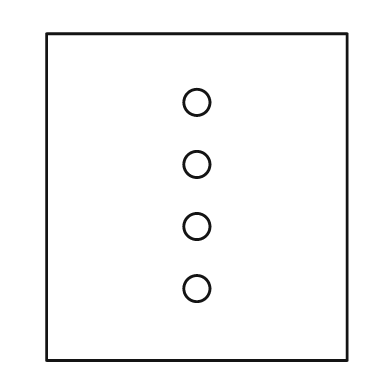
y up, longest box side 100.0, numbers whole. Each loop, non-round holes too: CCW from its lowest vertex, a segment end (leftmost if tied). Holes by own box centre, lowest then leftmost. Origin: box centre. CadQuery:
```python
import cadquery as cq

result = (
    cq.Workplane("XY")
    .moveTo(-46.0, -50.0)
    .lineTo(46.0, -50.0)
    .lineTo(46.0, 50.0)
    .lineTo(-46.0, 50.0)
    .close()
    .moveTo(0.0, -28.0)
    .circle(4.0)
    .moveTo(0.0, -9.0)
    .circle(4.0)
    .moveTo(0.0, 10.0)
    .circle(4.0)
    .moveTo(0.0, 29.0)
    .circle(4.0)
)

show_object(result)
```